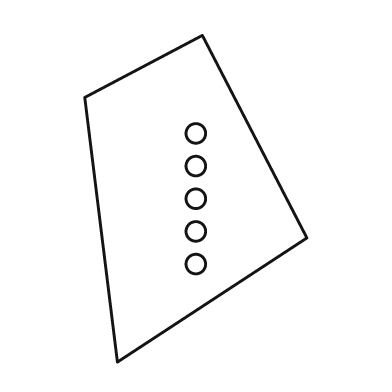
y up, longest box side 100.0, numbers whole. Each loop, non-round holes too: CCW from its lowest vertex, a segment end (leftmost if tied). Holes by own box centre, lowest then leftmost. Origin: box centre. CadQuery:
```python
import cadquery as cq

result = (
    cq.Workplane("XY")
    .moveTo(-24.0, -50.0)
    .lineTo(34.0, -12.0)
    .lineTo(2.0, 50.0)
    .lineTo(-34.0, 31.0)
    .close()
    .moveTo(0.0, -20.0)
    .circle(3.0)
    .moveTo(0.0, -10.0)
    .circle(3.0)
    .moveTo(0.0, 0.0)
    .circle(3.0)
    .moveTo(0.0, 10.0)
    .circle(3.0)
    .moveTo(0.0, 20.0)
    .circle(3.0)
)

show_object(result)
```